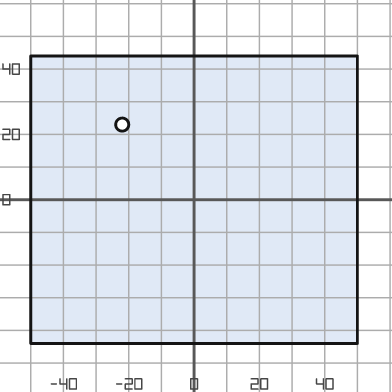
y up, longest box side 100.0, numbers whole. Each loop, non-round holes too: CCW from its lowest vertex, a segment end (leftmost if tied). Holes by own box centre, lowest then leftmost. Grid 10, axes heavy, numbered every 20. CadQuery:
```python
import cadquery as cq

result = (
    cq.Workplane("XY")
    .moveTo(-50.0, -44.0)
    .lineTo(50.0, -44.0)
    .lineTo(50.0, 44.0)
    .lineTo(-50.0, 44.0)
    .close()
    .moveTo(-22.0, 23.0)
    .circle(2.0)
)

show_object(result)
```